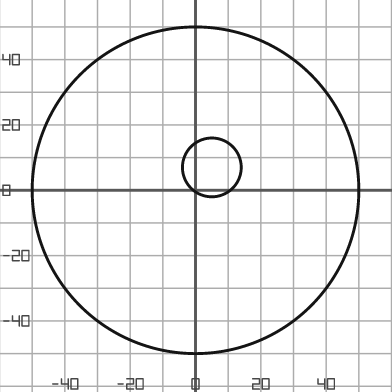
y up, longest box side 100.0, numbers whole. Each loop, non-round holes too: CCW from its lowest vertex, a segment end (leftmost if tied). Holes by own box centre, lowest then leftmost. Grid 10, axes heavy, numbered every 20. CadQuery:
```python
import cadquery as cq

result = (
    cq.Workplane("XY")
    .moveTo(0.0, 0.0)
    .circle(50.0)
    .moveTo(5.0, 7.0)
    .circle(9.0)
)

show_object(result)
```